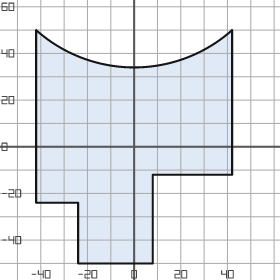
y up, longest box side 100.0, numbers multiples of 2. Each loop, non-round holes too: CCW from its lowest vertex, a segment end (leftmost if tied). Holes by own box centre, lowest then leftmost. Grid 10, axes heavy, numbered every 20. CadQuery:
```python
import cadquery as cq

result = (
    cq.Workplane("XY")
    .moveTo(-24.0, -50.0)
    .lineTo(8.0, -50.0)
    .lineTo(8.0, -12.0)
    .lineTo(42.0, -12.0)
    .lineTo(42.0, 50.0)
    .threePointArc((0.0, 34.0), (-42.0, 50.0))
    .lineTo(-42.0, -24.0)
    .lineTo(-24.0, -24.0)
    .close()
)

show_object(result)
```